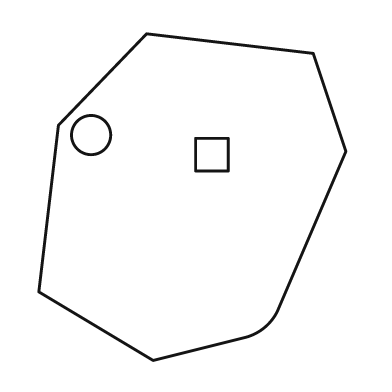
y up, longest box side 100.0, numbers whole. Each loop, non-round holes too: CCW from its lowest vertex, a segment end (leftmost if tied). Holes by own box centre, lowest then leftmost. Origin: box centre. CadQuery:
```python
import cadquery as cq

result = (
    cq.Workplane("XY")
    .moveTo(-12.0, -50.0)
    .lineTo(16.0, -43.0)
    .threePointArc((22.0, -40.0), (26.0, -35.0))
    .lineTo(47.0, 14.0)
    .lineTo(37.0, 44.0)
    .lineTo(-14.0, 50.0)
    .lineTo(-41.0, 22.0)
    .lineTo(-47.0, -29.0)
    .close()
    .moveTo(1.0, 8.0)
    .lineTo(11.0, 8.0)
    .lineTo(11.0, 18.0)
    .lineTo(1.0, 18.0)
    .close()
    .moveTo(-31.0, 19.0)
    .circle(6.0)
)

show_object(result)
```